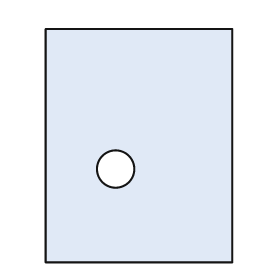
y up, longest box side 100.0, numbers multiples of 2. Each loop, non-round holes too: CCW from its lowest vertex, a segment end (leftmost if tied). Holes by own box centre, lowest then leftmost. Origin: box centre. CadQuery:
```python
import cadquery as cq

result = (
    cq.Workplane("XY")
    .moveTo(-40.0, -50.0)
    .lineTo(40.0, -50.0)
    .lineTo(40.0, 50.0)
    .lineTo(-40.0, 50.0)
    .close()
    .moveTo(-10.0, -10.0)
    .circle(8.0)
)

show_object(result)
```